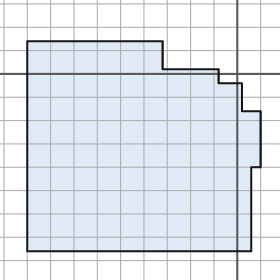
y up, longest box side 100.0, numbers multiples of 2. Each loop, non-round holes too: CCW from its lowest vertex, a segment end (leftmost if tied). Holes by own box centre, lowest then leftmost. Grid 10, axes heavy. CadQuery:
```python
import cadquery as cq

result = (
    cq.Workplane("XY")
    .moveTo(-90.0, -76.0)
    .lineTo(6.0, -76.0)
    .lineTo(6.0, -40.0)
    .lineTo(10.0, -40.0)
    .lineTo(10.0, -16.0)
    .lineTo(2.0, -16.0)
    .lineTo(2.0, -4.0)
    .lineTo(-8.0, -4.0)
    .lineTo(-8.0, 2.0)
    .lineTo(-32.0, 2.0)
    .lineTo(-32.0, 14.0)
    .lineTo(-90.0, 14.0)
    .close()
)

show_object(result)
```